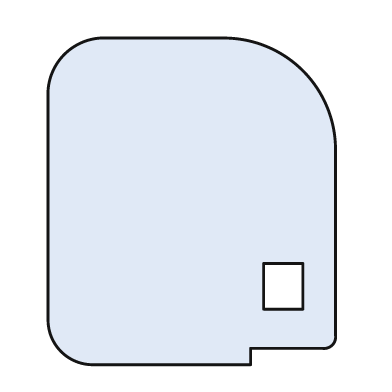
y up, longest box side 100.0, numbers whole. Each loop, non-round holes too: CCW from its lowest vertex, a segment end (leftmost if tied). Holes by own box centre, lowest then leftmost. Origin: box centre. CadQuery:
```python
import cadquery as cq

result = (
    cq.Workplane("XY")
    .moveTo(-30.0, -50.0)
    .lineTo(18.0, -50.0)
    .lineTo(18.0, -45.0)
    .lineTo(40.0, -45.0)
    .threePointArc((43.0, -44.0), (44.0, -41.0))
    .lineTo(44.0, 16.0)
    .threePointArc((34.0, 40.0), (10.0, 50.0))
    .lineTo(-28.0, 50.0)
    .threePointArc((-39.0, 45.0), (-44.0, 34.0))
    .lineTo(-44.0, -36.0)
    .threePointArc((-40.0, -46.0), (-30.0, -50.0))
    .close()
    .moveTo(22.0, -33.0)
    .lineTo(34.0, -33.0)
    .lineTo(34.0, -19.0)
    .lineTo(22.0, -19.0)
    .close()
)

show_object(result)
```